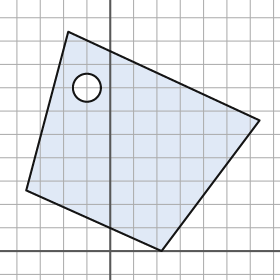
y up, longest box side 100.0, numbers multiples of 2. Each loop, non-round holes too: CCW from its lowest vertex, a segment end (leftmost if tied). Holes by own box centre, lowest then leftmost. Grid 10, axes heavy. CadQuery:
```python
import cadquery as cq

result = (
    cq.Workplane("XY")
    .moveTo(22.0, 0.0)
    .lineTo(64.0, 56.0)
    .lineTo(-18.0, 94.0)
    .lineTo(-36.0, 26.0)
    .close()
    .moveTo(-10.0, 70.0)
    .circle(6.0)
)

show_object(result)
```